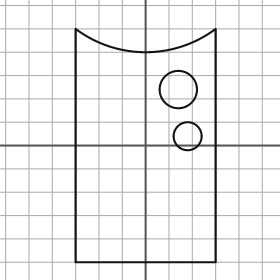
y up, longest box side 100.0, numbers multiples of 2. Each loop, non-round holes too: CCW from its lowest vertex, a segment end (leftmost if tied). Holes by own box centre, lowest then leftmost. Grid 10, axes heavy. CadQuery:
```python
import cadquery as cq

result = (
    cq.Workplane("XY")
    .moveTo(-30.0, -50.0)
    .lineTo(30.0, -50.0)
    .lineTo(30.0, 50.0)
    .threePointArc((0.0, 40.0), (-30.0, 50.0))
    .close()
    .moveTo(18.0, 4.0)
    .circle(6.0)
    .moveTo(14.0, 24.0)
    .circle(8.0)
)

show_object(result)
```